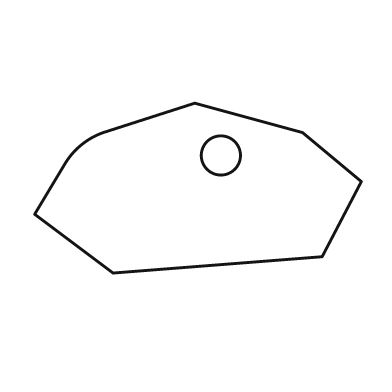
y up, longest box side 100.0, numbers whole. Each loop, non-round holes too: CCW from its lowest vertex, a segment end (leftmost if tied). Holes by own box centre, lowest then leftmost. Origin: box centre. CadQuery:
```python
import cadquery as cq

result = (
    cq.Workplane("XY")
    .moveTo(-26.0, -26.0)
    .lineTo(38.0, -21.0)
    .lineTo(50.0, 2.0)
    .lineTo(32.0, 17.0)
    .lineTo(-1.0, 26.0)
    .lineTo(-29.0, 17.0)
    .threePointArc((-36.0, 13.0), (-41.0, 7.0))
    .lineTo(-50.0, -8.0)
    .close()
    .moveTo(7.0, 10.0)
    .circle(6.0)
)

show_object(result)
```